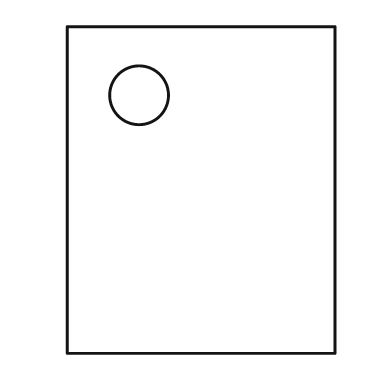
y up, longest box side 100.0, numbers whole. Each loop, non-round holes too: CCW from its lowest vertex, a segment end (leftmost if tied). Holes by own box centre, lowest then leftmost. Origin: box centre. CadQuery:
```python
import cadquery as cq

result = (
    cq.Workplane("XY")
    .moveTo(-41.0, -50.0)
    .lineTo(41.0, -50.0)
    .lineTo(41.0, 50.0)
    .lineTo(-41.0, 50.0)
    .close()
    .moveTo(-19.0, 29.0)
    .circle(9.0)
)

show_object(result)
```